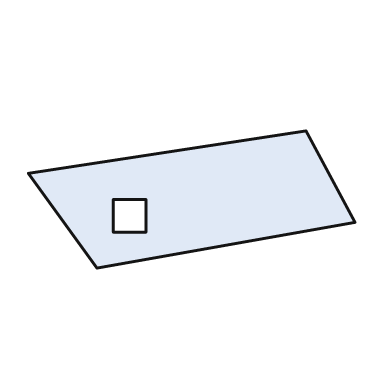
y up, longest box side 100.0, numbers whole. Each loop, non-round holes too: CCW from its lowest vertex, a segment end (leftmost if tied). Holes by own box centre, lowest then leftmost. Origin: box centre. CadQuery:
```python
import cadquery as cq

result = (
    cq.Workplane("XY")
    .moveTo(-29.0, -21.0)
    .lineTo(50.0, -7.0)
    .lineTo(35.0, 21.0)
    .lineTo(-50.0, 8.0)
    .close()
    .moveTo(-24.0, -10.0)
    .lineTo(-14.0, -10.0)
    .lineTo(-14.0, 0.0)
    .lineTo(-24.0, 0.0)
    .close()
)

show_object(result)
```